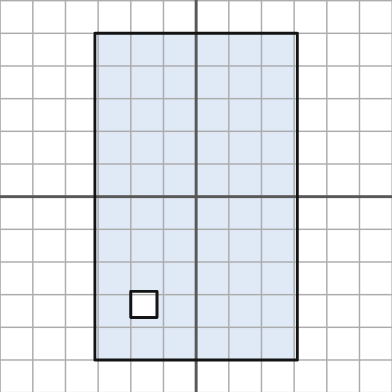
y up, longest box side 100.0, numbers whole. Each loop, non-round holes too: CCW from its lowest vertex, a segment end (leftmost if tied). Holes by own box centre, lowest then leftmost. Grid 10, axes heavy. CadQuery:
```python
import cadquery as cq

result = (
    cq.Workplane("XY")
    .moveTo(-31.0, -50.0)
    .lineTo(31.0, -50.0)
    .lineTo(31.0, 50.0)
    .lineTo(-31.0, 50.0)
    .close()
    .moveTo(-20.0, -37.0)
    .lineTo(-12.0, -37.0)
    .lineTo(-12.0, -29.0)
    .lineTo(-20.0, -29.0)
    .close()
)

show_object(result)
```